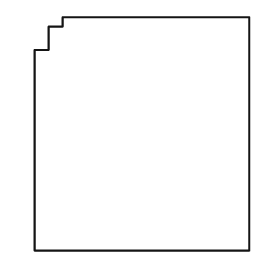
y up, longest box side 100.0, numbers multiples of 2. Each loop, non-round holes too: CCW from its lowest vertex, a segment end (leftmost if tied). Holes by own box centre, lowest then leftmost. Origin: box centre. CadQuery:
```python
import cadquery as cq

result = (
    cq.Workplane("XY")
    .moveTo(-46.0, -50.0)
    .lineTo(46.0, -50.0)
    .lineTo(46.0, 50.0)
    .lineTo(-34.0, 50.0)
    .lineTo(-34.0, 46.0)
    .lineTo(-40.0, 46.0)
    .lineTo(-40.0, 36.0)
    .lineTo(-46.0, 36.0)
    .close()
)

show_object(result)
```